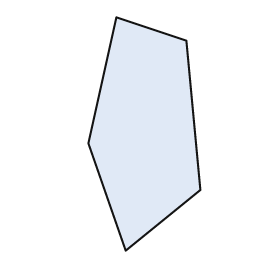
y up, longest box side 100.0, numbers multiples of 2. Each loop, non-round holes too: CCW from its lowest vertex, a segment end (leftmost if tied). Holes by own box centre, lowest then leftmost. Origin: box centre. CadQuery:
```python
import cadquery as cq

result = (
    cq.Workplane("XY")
    .moveTo(-8.0, -50.0)
    .lineTo(24.0, -24.0)
    .lineTo(18.0, 40.0)
    .lineTo(-12.0, 50.0)
    .lineTo(-24.0, -4.0)
    .close()
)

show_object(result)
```